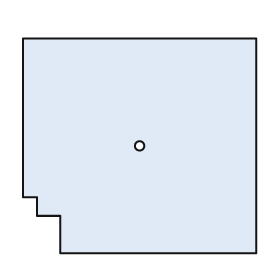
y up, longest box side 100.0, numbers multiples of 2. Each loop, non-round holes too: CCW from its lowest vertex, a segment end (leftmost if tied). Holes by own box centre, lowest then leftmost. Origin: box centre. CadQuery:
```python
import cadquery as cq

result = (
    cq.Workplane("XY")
    .moveTo(-34.0, -46.0)
    .lineTo(50.0, -46.0)
    .lineTo(50.0, 46.0)
    .lineTo(-50.0, 46.0)
    .lineTo(-50.0, -22.0)
    .lineTo(-44.0, -22.0)
    .lineTo(-44.0, -30.0)
    .lineTo(-34.0, -30.0)
    .close()
    .moveTo(0.0, 0.0)
    .circle(2.0)
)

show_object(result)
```